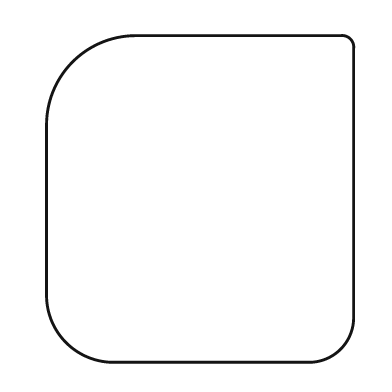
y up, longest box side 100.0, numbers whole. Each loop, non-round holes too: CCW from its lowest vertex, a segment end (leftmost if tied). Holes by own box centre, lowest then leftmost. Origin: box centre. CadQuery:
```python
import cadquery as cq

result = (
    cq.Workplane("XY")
    .moveTo(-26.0, -50.0)
    .lineTo(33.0, -50.0)
    .threePointArc((43.0, -46.0), (47.0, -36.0))
    .lineTo(47.0, 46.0)
    .threePointArc((46.0, 49.0), (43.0, 50.0))
    .lineTo(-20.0, 50.0)
    .threePointArc((-39.0, 42.0), (-47.0, 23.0))
    .lineTo(-47.0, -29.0)
    .threePointArc((-41.0, -44.0), (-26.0, -50.0))
    .close()
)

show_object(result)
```